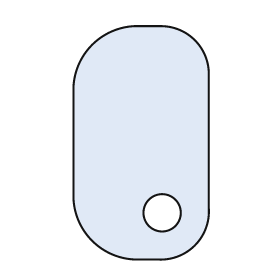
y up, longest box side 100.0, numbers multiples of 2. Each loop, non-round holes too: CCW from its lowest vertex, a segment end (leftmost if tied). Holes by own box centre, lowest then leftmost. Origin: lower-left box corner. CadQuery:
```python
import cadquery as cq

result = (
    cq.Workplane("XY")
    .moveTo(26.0, 0.0)
    .lineTo(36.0, 0.0)
    .threePointArc((52.0, 6.0), (58.0, 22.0))
    .lineTo(58.0, 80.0)
    .threePointArc((52.0, 94.0), (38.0, 100.0))
    .lineTo(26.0, 100.0)
    .threePointArc((8.0, 92.0), (0.0, 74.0))
    .lineTo(0.0, 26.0)
    .threePointArc((8.0, 8.0), (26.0, 0.0))
    .close()
    .moveTo(38.0, 20.0)
    .circle(8.0)
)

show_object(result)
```